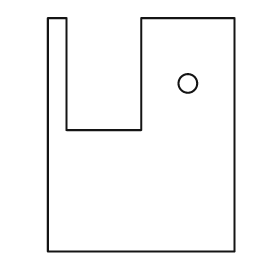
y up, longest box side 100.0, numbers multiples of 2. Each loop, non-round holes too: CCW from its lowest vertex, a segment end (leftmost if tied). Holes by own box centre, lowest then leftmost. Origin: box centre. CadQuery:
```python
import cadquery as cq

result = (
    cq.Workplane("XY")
    .moveTo(-40.0, -50.0)
    .lineTo(40.0, -50.0)
    .lineTo(40.0, 50.0)
    .lineTo(0.0, 50.0)
    .lineTo(0.0, 2.0)
    .lineTo(-32.0, 2.0)
    .lineTo(-32.0, 50.0)
    .lineTo(-40.0, 50.0)
    .close()
    .moveTo(20.0, 22.0)
    .circle(4.0)
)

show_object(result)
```